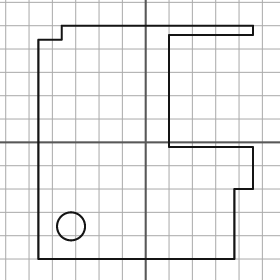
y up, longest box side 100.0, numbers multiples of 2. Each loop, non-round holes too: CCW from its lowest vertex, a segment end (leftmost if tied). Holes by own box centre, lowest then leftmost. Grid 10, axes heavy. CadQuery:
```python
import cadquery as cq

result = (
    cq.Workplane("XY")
    .moveTo(-46.0, -50.0)
    .lineTo(38.0, -50.0)
    .lineTo(38.0, -20.0)
    .lineTo(46.0, -20.0)
    .lineTo(46.0, -2.0)
    .lineTo(10.0, -2.0)
    .lineTo(10.0, 46.0)
    .lineTo(46.0, 46.0)
    .lineTo(46.0, 50.0)
    .lineTo(-36.0, 50.0)
    .lineTo(-36.0, 44.0)
    .lineTo(-46.0, 44.0)
    .close()
    .moveTo(-32.0, -36.0)
    .circle(6.0)
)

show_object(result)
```